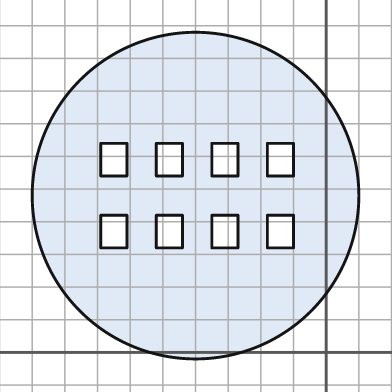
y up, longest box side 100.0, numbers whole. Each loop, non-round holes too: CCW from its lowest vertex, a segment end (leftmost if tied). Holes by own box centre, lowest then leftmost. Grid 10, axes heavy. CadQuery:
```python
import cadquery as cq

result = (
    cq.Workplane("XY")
    .moveTo(-40.0, 48.0)
    .circle(50.0)
    .moveTo(-69.0, 32.0)
    .lineTo(-61.0, 32.0)
    .lineTo(-61.0, 42.0)
    .lineTo(-69.0, 42.0)
    .close()
    .moveTo(-52.0, 32.0)
    .lineTo(-44.0, 32.0)
    .lineTo(-44.0, 42.0)
    .lineTo(-52.0, 42.0)
    .close()
    .moveTo(-35.0, 32.0)
    .lineTo(-27.0, 32.0)
    .lineTo(-27.0, 42.0)
    .lineTo(-35.0, 42.0)
    .close()
    .moveTo(-18.0, 32.0)
    .lineTo(-10.0, 32.0)
    .lineTo(-10.0, 42.0)
    .lineTo(-18.0, 42.0)
    .close()
    .moveTo(-69.0, 54.0)
    .lineTo(-61.0, 54.0)
    .lineTo(-61.0, 64.0)
    .lineTo(-69.0, 64.0)
    .close()
    .moveTo(-52.0, 54.0)
    .lineTo(-44.0, 54.0)
    .lineTo(-44.0, 64.0)
    .lineTo(-52.0, 64.0)
    .close()
    .moveTo(-35.0, 54.0)
    .lineTo(-27.0, 54.0)
    .lineTo(-27.0, 64.0)
    .lineTo(-35.0, 64.0)
    .close()
    .moveTo(-18.0, 54.0)
    .lineTo(-10.0, 54.0)
    .lineTo(-10.0, 64.0)
    .lineTo(-18.0, 64.0)
    .close()
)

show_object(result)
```